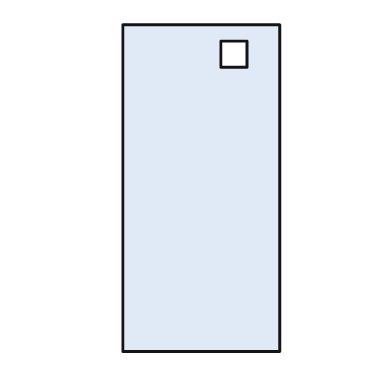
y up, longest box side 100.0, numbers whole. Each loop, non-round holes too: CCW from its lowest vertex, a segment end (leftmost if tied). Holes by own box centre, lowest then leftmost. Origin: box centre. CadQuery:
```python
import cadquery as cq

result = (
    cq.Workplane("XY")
    .moveTo(-24.0, -50.0)
    .lineTo(24.0, -50.0)
    .lineTo(24.0, 50.0)
    .lineTo(-24.0, 50.0)
    .close()
    .moveTo(6.0, 37.0)
    .lineTo(14.0, 37.0)
    .lineTo(14.0, 45.0)
    .lineTo(6.0, 45.0)
    .close()
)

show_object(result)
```